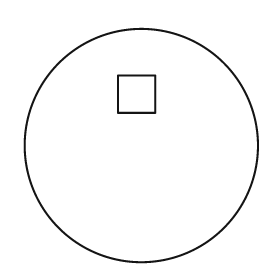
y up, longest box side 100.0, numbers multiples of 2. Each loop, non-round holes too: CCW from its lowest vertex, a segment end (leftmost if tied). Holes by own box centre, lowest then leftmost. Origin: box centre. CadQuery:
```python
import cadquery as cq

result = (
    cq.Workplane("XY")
    .moveTo(0.0, 0.0)
    .circle(50.0)
    .moveTo(-10.0, 14.0)
    .lineTo(6.0, 14.0)
    .lineTo(6.0, 30.0)
    .lineTo(-10.0, 30.0)
    .close()
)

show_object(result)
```